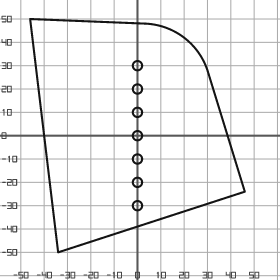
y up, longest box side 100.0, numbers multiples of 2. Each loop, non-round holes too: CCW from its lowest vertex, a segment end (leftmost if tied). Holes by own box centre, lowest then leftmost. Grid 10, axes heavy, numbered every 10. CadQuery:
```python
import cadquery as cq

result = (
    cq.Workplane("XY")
    .moveTo(-34.0, -50.0)
    .lineTo(46.0, -24.0)
    .lineTo(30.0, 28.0)
    .threePointArc((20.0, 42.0), (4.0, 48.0))
    .lineTo(-46.0, 50.0)
    .close()
    .moveTo(0.0, -30.0)
    .circle(2.0)
    .moveTo(0.0, -20.0)
    .circle(2.0)
    .moveTo(0.0, -10.0)
    .circle(2.0)
    .moveTo(0.0, 0.0)
    .circle(2.0)
    .moveTo(0.0, 10.0)
    .circle(2.0)
    .moveTo(0.0, 20.0)
    .circle(2.0)
    .moveTo(0.0, 30.0)
    .circle(2.0)
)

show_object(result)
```